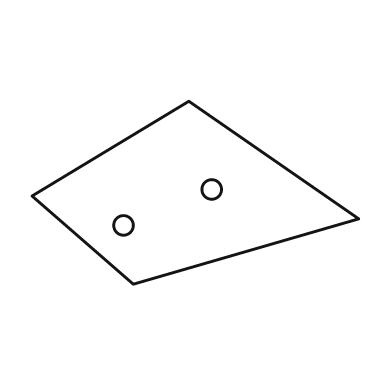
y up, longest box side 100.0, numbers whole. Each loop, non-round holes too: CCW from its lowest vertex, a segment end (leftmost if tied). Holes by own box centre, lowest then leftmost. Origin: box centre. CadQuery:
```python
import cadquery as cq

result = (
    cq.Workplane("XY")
    .moveTo(-19.0, -28.0)
    .lineTo(50.0, -8.0)
    .lineTo(-2.0, 28.0)
    .lineTo(-50.0, -1.0)
    .close()
    .moveTo(-22.0, -10.0)
    .circle(3.0)
    .moveTo(5.0, 1.0)
    .circle(3.0)
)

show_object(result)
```